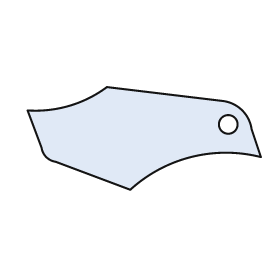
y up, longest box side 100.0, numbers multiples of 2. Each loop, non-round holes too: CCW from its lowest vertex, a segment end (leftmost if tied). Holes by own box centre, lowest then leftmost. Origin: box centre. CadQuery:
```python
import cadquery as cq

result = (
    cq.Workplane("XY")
    .moveTo(-6.0, -22.0)
    .threePointArc((20.0, -8.0), (50.0, -8.0))
    .lineTo(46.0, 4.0)
    .threePointArc((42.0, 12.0), (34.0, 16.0))
    .lineTo(-16.0, 22.0)
    .threePointArc((-32.0, 14.0), (-50.0, 12.0))
    .lineTo(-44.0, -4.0)
    .threePointArc((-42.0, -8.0), (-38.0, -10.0))
    .close()
    .moveTo(36.0, 6.0)
    .circle(4.0)
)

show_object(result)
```